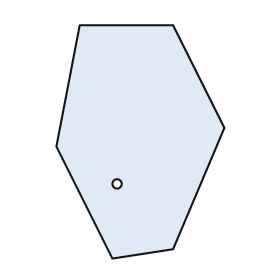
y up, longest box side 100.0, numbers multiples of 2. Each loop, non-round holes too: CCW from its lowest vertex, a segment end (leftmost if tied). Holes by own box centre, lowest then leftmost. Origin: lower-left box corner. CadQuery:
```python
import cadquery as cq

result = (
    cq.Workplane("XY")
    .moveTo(24.0, 0.0)
    .lineTo(50.0, 4.0)
    .lineTo(72.0, 56.0)
    .lineTo(50.0, 100.0)
    .lineTo(10.0, 100.0)
    .lineTo(0.0, 48.0)
    .close()
    .moveTo(26.0, 32.0)
    .circle(2.0)
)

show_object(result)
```